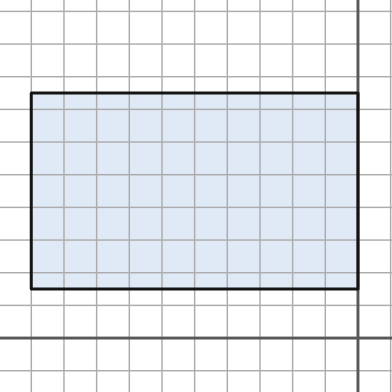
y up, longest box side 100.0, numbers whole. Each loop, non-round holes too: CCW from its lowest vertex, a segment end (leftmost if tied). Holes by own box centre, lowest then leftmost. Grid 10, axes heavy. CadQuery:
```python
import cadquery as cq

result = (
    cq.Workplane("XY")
    .moveTo(-100.0, 15.0)
    .lineTo(0.0, 15.0)
    .lineTo(0.0, 75.0)
    .lineTo(-100.0, 75.0)
    .close()
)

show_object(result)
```